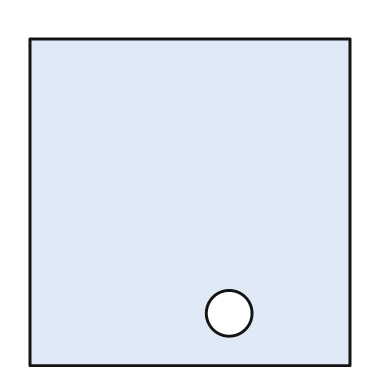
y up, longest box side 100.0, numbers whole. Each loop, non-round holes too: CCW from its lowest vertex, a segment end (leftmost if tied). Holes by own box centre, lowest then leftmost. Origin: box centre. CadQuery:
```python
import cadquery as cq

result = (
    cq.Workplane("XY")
    .moveTo(-49.0, -50.0)
    .lineTo(49.0, -50.0)
    .lineTo(49.0, 50.0)
    .lineTo(-49.0, 50.0)
    .close()
    .moveTo(12.0, -34.0)
    .circle(7.0)
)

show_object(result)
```